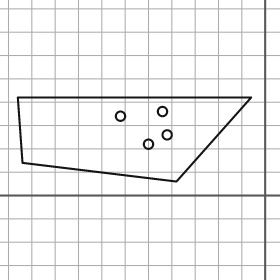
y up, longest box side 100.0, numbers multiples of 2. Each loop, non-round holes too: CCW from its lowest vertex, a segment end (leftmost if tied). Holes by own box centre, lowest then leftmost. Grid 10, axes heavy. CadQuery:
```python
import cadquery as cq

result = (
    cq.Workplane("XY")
    .moveTo(-38.0, 6.0)
    .lineTo(-6.0, 42.0)
    .lineTo(-106.0, 42.0)
    .lineTo(-104.0, 14.0)
    .close()
    .moveTo(-50.0, 22.0)
    .circle(2.0)
    .moveTo(-42.0, 26.0)
    .circle(2.0)
    .moveTo(-62.0, 34.0)
    .circle(2.0)
    .moveTo(-44.0, 36.0)
    .circle(2.0)
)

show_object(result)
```